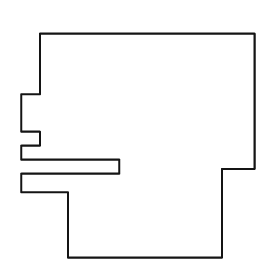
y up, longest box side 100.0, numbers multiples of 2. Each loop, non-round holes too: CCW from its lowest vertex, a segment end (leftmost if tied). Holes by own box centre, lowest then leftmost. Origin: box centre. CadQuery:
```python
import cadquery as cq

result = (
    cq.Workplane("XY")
    .moveTo(-30.0, -48.0)
    .lineTo(36.0, -48.0)
    .lineTo(36.0, -10.0)
    .lineTo(50.0, -10.0)
    .lineTo(50.0, 48.0)
    .lineTo(-42.0, 48.0)
    .lineTo(-42.0, 22.0)
    .lineTo(-50.0, 22.0)
    .lineTo(-50.0, 6.0)
    .lineTo(-42.0, 6.0)
    .lineTo(-42.0, 0.0)
    .lineTo(-50.0, 0.0)
    .lineTo(-50.0, -6.0)
    .lineTo(-8.0, -6.0)
    .lineTo(-8.0, -12.0)
    .lineTo(-50.0, -12.0)
    .lineTo(-50.0, -20.0)
    .lineTo(-30.0, -20.0)
    .close()
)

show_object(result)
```